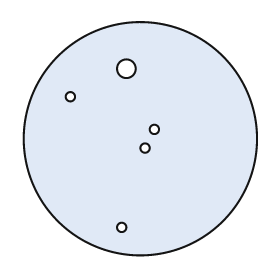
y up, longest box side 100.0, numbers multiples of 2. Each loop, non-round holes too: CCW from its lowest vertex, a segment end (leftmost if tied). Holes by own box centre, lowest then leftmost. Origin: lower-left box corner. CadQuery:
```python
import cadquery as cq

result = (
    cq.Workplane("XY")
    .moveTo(50.0, 50.0)
    .circle(50.0)
    .moveTo(42.0, 12.0)
    .circle(2.0)
    .moveTo(52.0, 46.0)
    .circle(2.0)
    .moveTo(56.0, 54.0)
    .circle(2.0)
    .moveTo(20.0, 68.0)
    .circle(2.0)
    .moveTo(44.0, 80.0)
    .circle(4.0)
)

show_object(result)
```